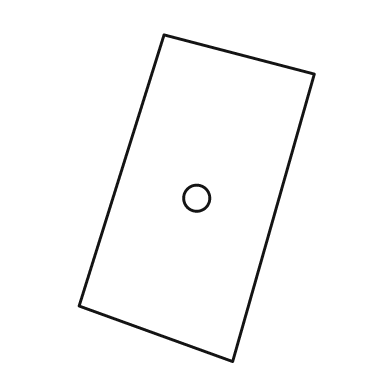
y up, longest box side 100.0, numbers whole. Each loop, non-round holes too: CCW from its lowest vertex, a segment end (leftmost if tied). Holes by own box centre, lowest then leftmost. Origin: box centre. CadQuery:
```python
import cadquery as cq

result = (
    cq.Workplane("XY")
    .moveTo(11.0, -50.0)
    .lineTo(36.0, 38.0)
    .lineTo(-10.0, 50.0)
    .lineTo(-36.0, -33.0)
    .close()
    .moveTo(0.0, 0.0)
    .circle(4.0)
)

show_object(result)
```